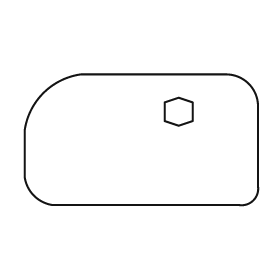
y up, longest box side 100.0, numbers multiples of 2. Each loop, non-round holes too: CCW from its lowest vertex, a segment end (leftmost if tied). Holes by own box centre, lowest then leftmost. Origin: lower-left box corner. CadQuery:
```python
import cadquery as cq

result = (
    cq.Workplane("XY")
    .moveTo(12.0, 0.0)
    .lineTo(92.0, 0.0)
    .threePointArc((98.0, 2.0), (100.0, 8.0))
    .lineTo(100.0, 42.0)
    .threePointArc((96.0, 52.0), (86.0, 56.0))
    .lineTo(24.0, 56.0)
    .threePointArc((8.0, 48.0), (0.0, 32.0))
    .lineTo(0.0, 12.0)
    .threePointArc((4.0, 4.0), (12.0, 0.0))
    .close()
    .moveTo(66.0, 34.0)
    .lineTo(72.0, 36.0)
    .lineTo(72.0, 44.0)
    .lineTo(66.0, 46.0)
    .lineTo(60.0, 44.0)
    .lineTo(60.0, 36.0)
    .close()
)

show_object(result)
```